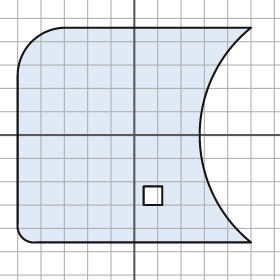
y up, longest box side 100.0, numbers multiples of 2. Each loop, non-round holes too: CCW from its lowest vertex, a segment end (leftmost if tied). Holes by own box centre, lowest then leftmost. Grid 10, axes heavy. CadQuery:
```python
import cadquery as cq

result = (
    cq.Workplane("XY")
    .moveTo(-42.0, -46.0)
    .lineTo(50.0, -46.0)
    .threePointArc((28.0, 0.0), (50.0, 46.0))
    .lineTo(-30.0, 46.0)
    .threePointArc((-44.0, 40.0), (-50.0, 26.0))
    .lineTo(-50.0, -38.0)
    .threePointArc((-48.0, -44.0), (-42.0, -46.0))
    .close()
    .moveTo(4.0, -30.0)
    .lineTo(12.0, -30.0)
    .lineTo(12.0, -22.0)
    .lineTo(4.0, -22.0)
    .close()
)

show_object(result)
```